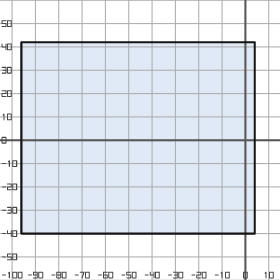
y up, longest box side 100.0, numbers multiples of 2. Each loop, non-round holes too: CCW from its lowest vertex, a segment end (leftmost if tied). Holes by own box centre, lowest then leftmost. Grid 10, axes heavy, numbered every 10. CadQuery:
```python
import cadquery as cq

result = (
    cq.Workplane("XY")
    .moveTo(-96.0, -40.0)
    .lineTo(4.0, -40.0)
    .lineTo(4.0, 42.0)
    .lineTo(-96.0, 42.0)
    .close()
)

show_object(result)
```